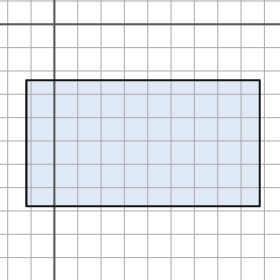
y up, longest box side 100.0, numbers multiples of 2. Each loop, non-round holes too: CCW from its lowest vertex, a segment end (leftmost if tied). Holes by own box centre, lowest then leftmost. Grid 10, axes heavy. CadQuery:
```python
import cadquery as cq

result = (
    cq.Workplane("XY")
    .moveTo(-12.0, -78.0)
    .lineTo(88.0, -78.0)
    .lineTo(88.0, -24.0)
    .lineTo(-12.0, -24.0)
    .close()
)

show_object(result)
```